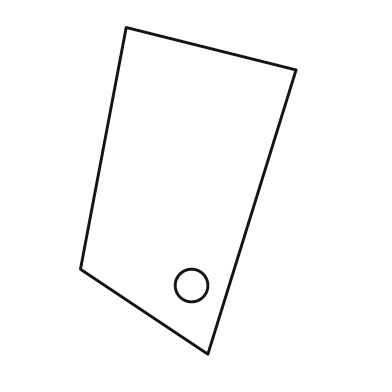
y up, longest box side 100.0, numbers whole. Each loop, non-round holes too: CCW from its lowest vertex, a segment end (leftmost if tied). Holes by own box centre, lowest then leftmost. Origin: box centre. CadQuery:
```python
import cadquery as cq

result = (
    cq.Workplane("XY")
    .moveTo(6.0, -50.0)
    .lineTo(33.0, 37.0)
    .lineTo(-19.0, 50.0)
    .lineTo(-33.0, -24.0)
    .close()
    .moveTo(1.0, -29.0)
    .circle(5.0)
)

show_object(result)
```